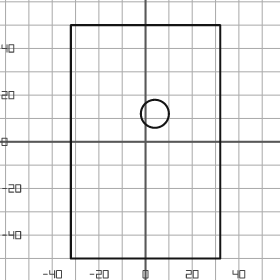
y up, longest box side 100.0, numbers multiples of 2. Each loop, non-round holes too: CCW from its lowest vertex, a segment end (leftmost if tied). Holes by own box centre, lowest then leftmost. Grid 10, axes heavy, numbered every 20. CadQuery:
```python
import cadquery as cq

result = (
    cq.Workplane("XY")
    .moveTo(-32.0, -50.0)
    .lineTo(32.0, -50.0)
    .lineTo(32.0, 50.0)
    .lineTo(-32.0, 50.0)
    .close()
    .moveTo(4.0, 12.0)
    .circle(6.0)
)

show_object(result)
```